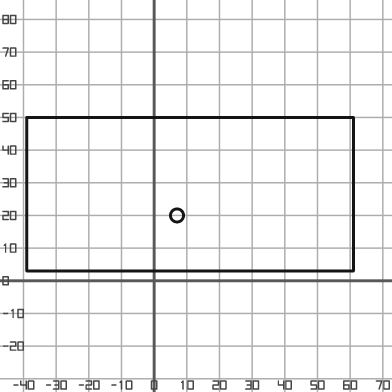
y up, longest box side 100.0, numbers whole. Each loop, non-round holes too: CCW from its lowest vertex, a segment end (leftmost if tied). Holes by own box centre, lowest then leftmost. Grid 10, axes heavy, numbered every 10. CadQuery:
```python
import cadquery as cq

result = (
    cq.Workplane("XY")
    .moveTo(-39.0, 3.0)
    .lineTo(61.0, 3.0)
    .lineTo(61.0, 50.0)
    .lineTo(-39.0, 50.0)
    .close()
    .moveTo(7.0, 20.0)
    .circle(2.0)
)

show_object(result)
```